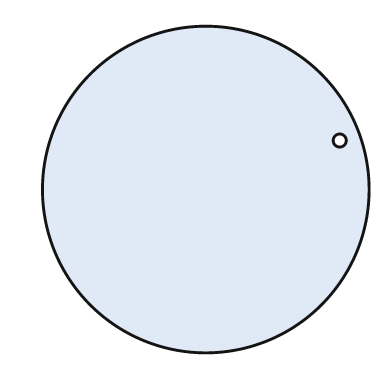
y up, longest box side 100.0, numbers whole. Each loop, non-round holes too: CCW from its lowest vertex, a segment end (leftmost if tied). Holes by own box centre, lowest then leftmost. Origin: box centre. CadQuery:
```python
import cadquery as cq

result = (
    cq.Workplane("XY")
    .moveTo(0.0, 0.0)
    .circle(50.0)
    .moveTo(41.0, 15.0)
    .circle(2.0)
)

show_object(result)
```